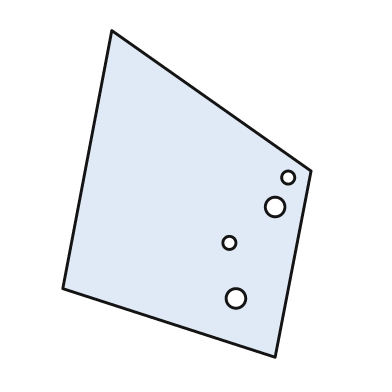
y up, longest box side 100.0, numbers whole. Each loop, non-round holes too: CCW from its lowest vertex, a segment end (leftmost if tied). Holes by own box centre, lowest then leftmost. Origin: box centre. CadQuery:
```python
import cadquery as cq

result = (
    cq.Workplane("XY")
    .moveTo(27.0, -50.0)
    .lineTo(38.0, 7.0)
    .lineTo(-23.0, 50.0)
    .lineTo(-38.0, -29.0)
    .close()
    .moveTo(15.0, -32.0)
    .circle(3.0)
    .moveTo(13.0, -15.0)
    .circle(2.0)
    .moveTo(27.0, -4.0)
    .circle(3.0)
    .moveTo(31.0, 5.0)
    .circle(2.0)
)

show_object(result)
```